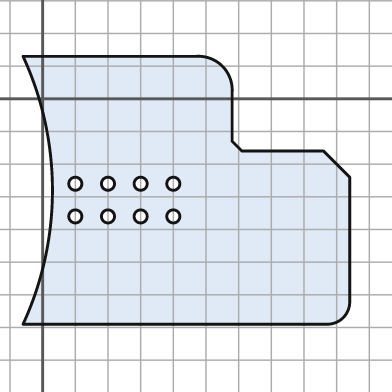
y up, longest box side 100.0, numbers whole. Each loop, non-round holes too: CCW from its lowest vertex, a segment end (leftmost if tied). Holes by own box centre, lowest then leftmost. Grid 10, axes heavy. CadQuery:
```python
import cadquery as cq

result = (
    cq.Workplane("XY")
    .moveTo(-6.0, -69.0)
    .lineTo(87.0, -69.0)
    .threePointArc((92.0, -67.0), (94.0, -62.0))
    .lineTo(94.0, -24.0)
    .lineTo(86.0, -16.0)
    .lineTo(61.0, -16.0)
    .lineTo(58.0, -13.0)
    .lineTo(58.0, 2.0)
    .threePointArc((55.0, 10.0), (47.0, 13.0))
    .lineTo(-6.0, 13.0)
    .threePointArc((3.0, -28.0), (-6.0, -69.0))
    .close()
    .moveTo(10.0, -36.0)
    .circle(2.0)
    .moveTo(20.0, -36.0)
    .circle(2.0)
    .moveTo(30.0, -36.0)
    .circle(2.0)
    .moveTo(40.0, -36.0)
    .circle(2.0)
    .moveTo(10.0, -26.0)
    .circle(2.0)
    .moveTo(20.0, -26.0)
    .circle(2.0)
    .moveTo(30.0, -26.0)
    .circle(2.0)
    .moveTo(40.0, -26.0)
    .circle(2.0)
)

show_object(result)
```